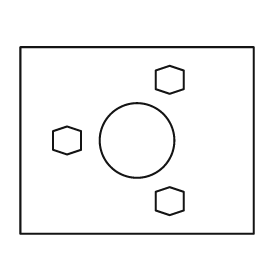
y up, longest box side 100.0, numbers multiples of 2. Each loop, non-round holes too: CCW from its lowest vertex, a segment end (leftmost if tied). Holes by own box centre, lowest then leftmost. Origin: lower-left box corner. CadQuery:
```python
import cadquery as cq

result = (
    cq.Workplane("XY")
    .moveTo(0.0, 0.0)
    .lineTo(100.0, 0.0)
    .lineTo(100.0, 80.0)
    .lineTo(0.0, 80.0)
    .close()
    .moveTo(64.0, 8.0)
    .lineTo(70.0, 10.0)
    .lineTo(70.0, 18.0)
    .lineTo(64.0, 20.0)
    .lineTo(58.0, 18.0)
    .lineTo(58.0, 10.0)
    .close()
    .moveTo(20.0, 34.0)
    .lineTo(26.0, 36.0)
    .lineTo(26.0, 44.0)
    .lineTo(20.0, 46.0)
    .lineTo(14.0, 44.0)
    .lineTo(14.0, 36.0)
    .close()
    .moveTo(50.0, 40.0)
    .circle(16.0)
    .moveTo(64.0, 60.0)
    .lineTo(70.0, 62.0)
    .lineTo(70.0, 70.0)
    .lineTo(64.0, 72.0)
    .lineTo(58.0, 70.0)
    .lineTo(58.0, 62.0)
    .close()
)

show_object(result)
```